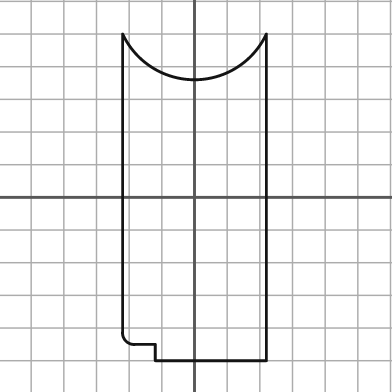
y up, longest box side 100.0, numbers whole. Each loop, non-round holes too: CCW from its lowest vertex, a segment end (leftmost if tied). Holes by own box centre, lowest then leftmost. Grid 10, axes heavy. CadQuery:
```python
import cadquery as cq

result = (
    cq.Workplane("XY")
    .moveTo(-12.0, -50.0)
    .lineTo(22.0, -50.0)
    .lineTo(22.0, 50.0)
    .threePointArc((0.0, 36.0), (-22.0, 50.0))
    .lineTo(-22.0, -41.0)
    .threePointArc((-21.0, -44.0), (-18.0, -45.0))
    .lineTo(-12.0, -45.0)
    .close()
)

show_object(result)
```